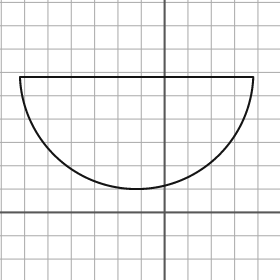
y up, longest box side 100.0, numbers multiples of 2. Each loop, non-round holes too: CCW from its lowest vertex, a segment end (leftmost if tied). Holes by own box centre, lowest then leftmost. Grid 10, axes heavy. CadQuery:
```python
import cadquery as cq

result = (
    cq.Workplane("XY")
    .moveTo(-62.0, 58.0)
    .threePointArc((-12.0, 10.0), (38.0, 58.0))
    .close()
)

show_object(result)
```